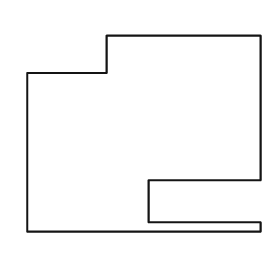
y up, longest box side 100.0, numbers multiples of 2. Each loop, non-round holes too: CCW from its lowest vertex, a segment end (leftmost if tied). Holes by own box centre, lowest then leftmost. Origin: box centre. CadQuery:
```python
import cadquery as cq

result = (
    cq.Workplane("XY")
    .moveTo(-50.0, -42.0)
    .lineTo(50.0, -42.0)
    .lineTo(50.0, -38.0)
    .lineTo(2.0, -38.0)
    .lineTo(2.0, -20.0)
    .lineTo(50.0, -20.0)
    .lineTo(50.0, 42.0)
    .lineTo(-16.0, 42.0)
    .lineTo(-16.0, 26.0)
    .lineTo(-50.0, 26.0)
    .close()
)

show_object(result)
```